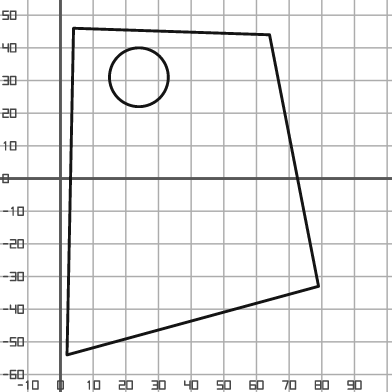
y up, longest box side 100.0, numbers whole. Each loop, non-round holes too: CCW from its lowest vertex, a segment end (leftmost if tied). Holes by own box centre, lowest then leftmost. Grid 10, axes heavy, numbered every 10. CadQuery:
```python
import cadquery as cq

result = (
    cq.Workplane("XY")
    .moveTo(2.0, -54.0)
    .lineTo(79.0, -33.0)
    .lineTo(64.0, 44.0)
    .lineTo(4.0, 46.0)
    .close()
    .moveTo(24.0, 31.0)
    .circle(9.0)
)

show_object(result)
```